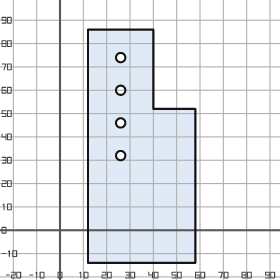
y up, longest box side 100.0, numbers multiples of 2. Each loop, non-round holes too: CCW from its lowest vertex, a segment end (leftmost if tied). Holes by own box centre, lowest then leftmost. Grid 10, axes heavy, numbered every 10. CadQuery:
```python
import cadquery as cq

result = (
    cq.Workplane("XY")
    .moveTo(12.0, -14.0)
    .lineTo(58.0, -14.0)
    .lineTo(58.0, 52.0)
    .lineTo(40.0, 52.0)
    .lineTo(40.0, 86.0)
    .lineTo(12.0, 86.0)
    .close()
    .moveTo(26.0, 32.0)
    .circle(2.0)
    .moveTo(26.0, 46.0)
    .circle(2.0)
    .moveTo(26.0, 60.0)
    .circle(2.0)
    .moveTo(26.0, 74.0)
    .circle(2.0)
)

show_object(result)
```